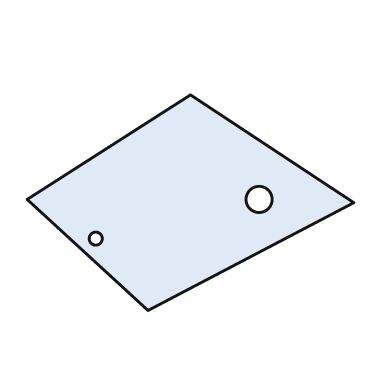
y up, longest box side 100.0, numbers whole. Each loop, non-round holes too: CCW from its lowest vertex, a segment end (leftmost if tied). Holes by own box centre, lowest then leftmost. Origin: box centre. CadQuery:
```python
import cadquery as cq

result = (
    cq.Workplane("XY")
    .moveTo(-13.0, -33.0)
    .lineTo(50.0, 0.0)
    .lineTo(0.0, 33.0)
    .lineTo(-50.0, 1.0)
    .close()
    .moveTo(-29.0, -11.0)
    .circle(2.0)
    .moveTo(21.0, 1.0)
    .circle(4.0)
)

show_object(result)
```